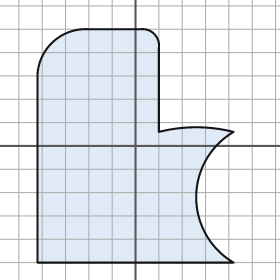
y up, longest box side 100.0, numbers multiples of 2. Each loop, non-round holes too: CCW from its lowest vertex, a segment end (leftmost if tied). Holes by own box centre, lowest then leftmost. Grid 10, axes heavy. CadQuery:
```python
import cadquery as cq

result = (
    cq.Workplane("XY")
    .moveTo(-42.0, -50.0)
    .lineTo(42.0, -50.0)
    .threePointArc((26.0, -22.0), (42.0, 6.0))
    .threePointArc((26.0, 8.0), (10.0, 6.0))
    .lineTo(10.0, 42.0)
    .threePointArc((8.0, 48.0), (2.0, 50.0))
    .lineTo(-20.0, 50.0)
    .threePointArc((-36.0, 44.0), (-42.0, 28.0))
    .close()
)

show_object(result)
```